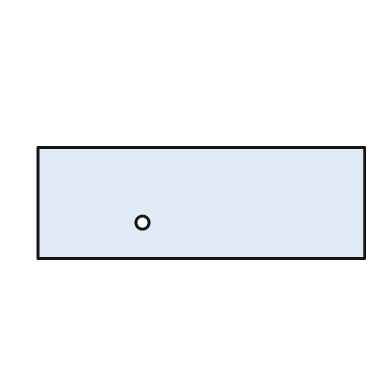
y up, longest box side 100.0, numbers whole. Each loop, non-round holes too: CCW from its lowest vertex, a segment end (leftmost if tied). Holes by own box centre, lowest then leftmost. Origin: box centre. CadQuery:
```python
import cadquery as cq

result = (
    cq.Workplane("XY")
    .moveTo(-50.0, -17.0)
    .lineTo(50.0, -17.0)
    .lineTo(50.0, 17.0)
    .lineTo(-50.0, 17.0)
    .close()
    .moveTo(-18.0, -6.0)
    .circle(2.0)
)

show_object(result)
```